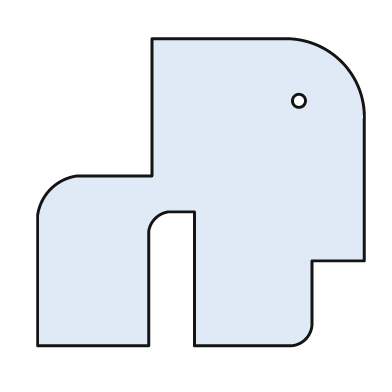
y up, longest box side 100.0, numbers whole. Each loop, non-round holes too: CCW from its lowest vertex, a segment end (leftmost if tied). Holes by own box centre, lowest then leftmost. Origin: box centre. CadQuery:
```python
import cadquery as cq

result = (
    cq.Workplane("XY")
    .moveTo(-50.0, -47.0)
    .lineTo(-16.0, -47.0)
    .lineTo(-16.0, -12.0)
    .threePointArc((-14.0, -8.0), (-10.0, -6.0))
    .lineTo(-2.0, -6.0)
    .lineTo(-2.0, -47.0)
    .lineTo(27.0, -47.0)
    .threePointArc((32.0, -45.0), (34.0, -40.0))
    .lineTo(34.0, -21.0)
    .lineTo(50.0, -21.0)
    .lineTo(50.0, 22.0)
    .threePointArc((43.0, 40.0), (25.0, 47.0))
    .lineTo(-15.0, 47.0)
    .lineTo(-15.0, 5.0)
    .lineTo(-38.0, 5.0)
    .threePointArc((-46.0, 1.0), (-50.0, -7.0))
    .close()
    .moveTo(30.0, 28.0)
    .circle(2.0)
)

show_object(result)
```